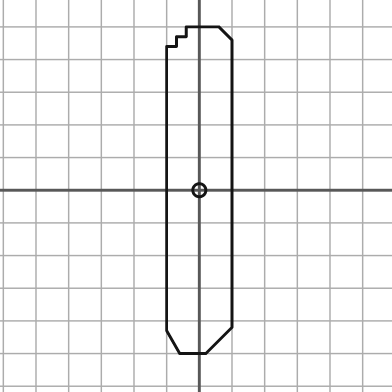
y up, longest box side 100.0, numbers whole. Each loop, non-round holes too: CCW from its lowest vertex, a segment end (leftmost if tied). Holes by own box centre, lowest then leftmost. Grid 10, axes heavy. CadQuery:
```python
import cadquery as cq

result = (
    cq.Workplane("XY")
    .moveTo(-6.0, -50.0)
    .lineTo(2.0, -50.0)
    .lineTo(10.0, -42.0)
    .lineTo(10.0, 46.0)
    .lineTo(6.0, 50.0)
    .lineTo(-4.0, 50.0)
    .lineTo(-4.0, 47.0)
    .lineTo(-7.0, 47.0)
    .lineTo(-7.0, 44.0)
    .lineTo(-10.0, 44.0)
    .lineTo(-10.0, -43.0)
    .close()
    .moveTo(0.0, 0.0)
    .circle(2.0)
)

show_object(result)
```